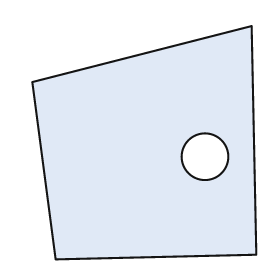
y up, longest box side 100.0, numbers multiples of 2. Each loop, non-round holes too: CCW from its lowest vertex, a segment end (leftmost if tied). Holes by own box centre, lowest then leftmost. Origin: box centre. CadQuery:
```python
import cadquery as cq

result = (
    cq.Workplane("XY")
    .moveTo(-38.0, -50.0)
    .lineTo(48.0, -48.0)
    .lineTo(46.0, 50.0)
    .lineTo(-48.0, 26.0)
    .close()
    .moveTo(26.0, -6.0)
    .circle(10.0)
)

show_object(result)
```